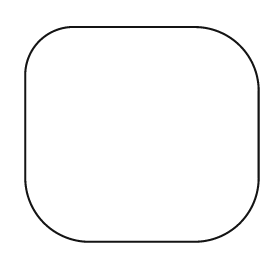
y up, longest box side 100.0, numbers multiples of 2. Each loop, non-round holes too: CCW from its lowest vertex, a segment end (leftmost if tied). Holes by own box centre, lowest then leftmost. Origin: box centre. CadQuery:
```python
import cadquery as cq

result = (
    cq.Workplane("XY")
    .moveTo(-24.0, -46.0)
    .lineTo(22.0, -46.0)
    .threePointArc((42.0, -38.0), (50.0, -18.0))
    .lineTo(50.0, 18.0)
    .threePointArc((42.0, 38.0), (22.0, 46.0))
    .lineTo(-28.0, 46.0)
    .threePointArc((-44.0, 40.0), (-50.0, 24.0))
    .lineTo(-50.0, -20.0)
    .threePointArc((-42.0, -38.0), (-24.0, -46.0))
    .close()
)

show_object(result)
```